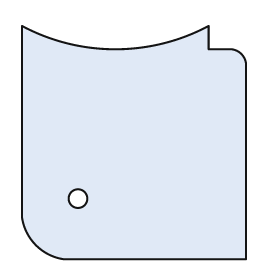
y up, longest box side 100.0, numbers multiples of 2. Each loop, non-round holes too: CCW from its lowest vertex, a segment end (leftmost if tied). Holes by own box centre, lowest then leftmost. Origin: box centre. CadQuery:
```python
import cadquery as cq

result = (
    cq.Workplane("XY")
    .moveTo(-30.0, -50.0)
    .lineTo(48.0, -50.0)
    .lineTo(48.0, 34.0)
    .threePointArc((46.0, 38.0), (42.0, 40.0))
    .lineTo(32.0, 40.0)
    .lineTo(32.0, 50.0)
    .threePointArc((-8.0, 40.0), (-48.0, 50.0))
    .lineTo(-48.0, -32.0)
    .threePointArc((-42.0, -44.0), (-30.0, -50.0))
    .close()
    .moveTo(-24.0, -24.0)
    .circle(4.0)
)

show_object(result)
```